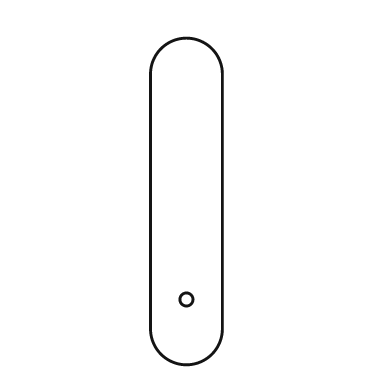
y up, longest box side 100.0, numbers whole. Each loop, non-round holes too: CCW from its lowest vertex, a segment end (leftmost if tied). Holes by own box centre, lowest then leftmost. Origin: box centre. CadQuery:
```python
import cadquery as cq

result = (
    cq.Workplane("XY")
    .moveTo(-11.0, -39.0)
    .threePointArc((0.0, -50.0), (11.0, -39.0))
    .lineTo(11.0, 39.0)
    .threePointArc((0.0, 50.0), (-11.0, 39.0))
    .close()
    .moveTo(0.0, -30.0)
    .circle(2.0)
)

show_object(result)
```